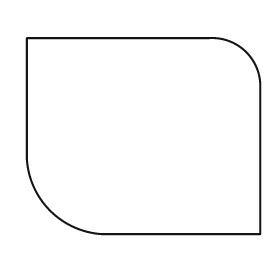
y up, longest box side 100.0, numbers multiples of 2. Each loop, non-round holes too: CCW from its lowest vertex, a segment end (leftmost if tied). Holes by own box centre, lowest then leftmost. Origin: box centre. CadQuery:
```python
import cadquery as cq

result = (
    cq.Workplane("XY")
    .moveTo(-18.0, -42.0)
    .lineTo(50.0, -42.0)
    .lineTo(50.0, 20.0)
    .threePointArc((44.0, 36.0), (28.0, 42.0))
    .lineTo(-50.0, 42.0)
    .lineTo(-50.0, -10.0)
    .threePointArc((-40.0, -32.0), (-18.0, -42.0))
    .close()
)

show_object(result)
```